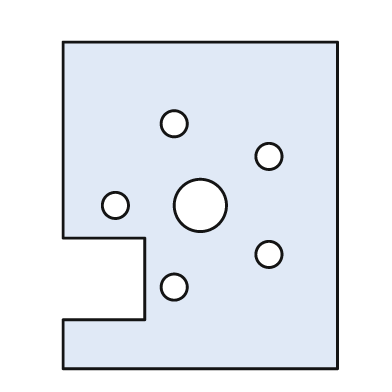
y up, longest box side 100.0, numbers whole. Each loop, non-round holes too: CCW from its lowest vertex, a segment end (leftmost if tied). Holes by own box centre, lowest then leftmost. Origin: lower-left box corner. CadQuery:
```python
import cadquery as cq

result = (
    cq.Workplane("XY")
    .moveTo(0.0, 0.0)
    .lineTo(84.0, 0.0)
    .lineTo(84.0, 100.0)
    .lineTo(0.0, 100.0)
    .lineTo(0.0, 40.0)
    .lineTo(25.0, 40.0)
    .lineTo(25.0, 15.0)
    .lineTo(0.0, 15.0)
    .close()
    .moveTo(34.0, 25.0)
    .circle(4.0)
    .moveTo(63.0, 35.0)
    .circle(4.0)
    .moveTo(16.0, 50.0)
    .circle(4.0)
    .moveTo(42.0, 50.0)
    .circle(8.0)
    .moveTo(63.0, 65.0)
    .circle(4.0)
    .moveTo(34.0, 75.0)
    .circle(4.0)
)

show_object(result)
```